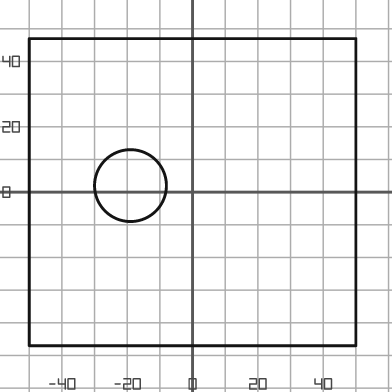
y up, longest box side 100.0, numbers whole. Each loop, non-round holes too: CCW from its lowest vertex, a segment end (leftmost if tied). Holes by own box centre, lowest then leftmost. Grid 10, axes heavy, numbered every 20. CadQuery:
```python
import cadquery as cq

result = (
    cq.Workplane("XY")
    .moveTo(-50.0, -47.0)
    .lineTo(50.0, -47.0)
    .lineTo(50.0, 47.0)
    .lineTo(-50.0, 47.0)
    .close()
    .moveTo(-19.0, 2.0)
    .circle(11.0)
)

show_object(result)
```